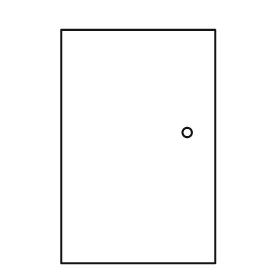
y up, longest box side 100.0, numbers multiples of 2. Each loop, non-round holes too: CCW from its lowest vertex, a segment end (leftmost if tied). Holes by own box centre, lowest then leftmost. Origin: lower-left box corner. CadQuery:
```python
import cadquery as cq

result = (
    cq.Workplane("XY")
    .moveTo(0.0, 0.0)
    .lineTo(66.0, 0.0)
    .lineTo(66.0, 100.0)
    .lineTo(0.0, 100.0)
    .close()
    .moveTo(54.0, 56.0)
    .circle(2.0)
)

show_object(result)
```